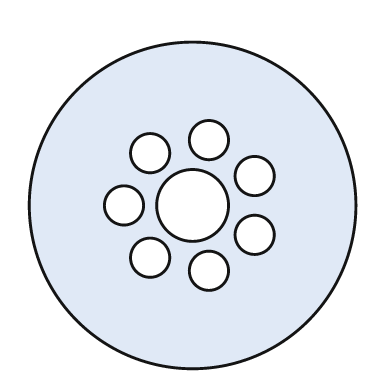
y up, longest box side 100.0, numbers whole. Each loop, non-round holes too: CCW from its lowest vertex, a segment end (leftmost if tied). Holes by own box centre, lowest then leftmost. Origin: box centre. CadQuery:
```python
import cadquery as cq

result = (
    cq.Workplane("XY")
    .moveTo(0.0, 0.0)
    .circle(50.0)
    .moveTo(5.0, -20.0)
    .circle(6.0)
    .moveTo(-13.0, -16.0)
    .circle(6.0)
    .moveTo(19.0, -9.0)
    .circle(6.0)
    .moveTo(-21.0, 0.0)
    .circle(6.0)
    .moveTo(0.0, 0.0)
    .circle(11.0)
    .moveTo(19.0, 9.0)
    .circle(6.0)
    .moveTo(-13.0, 16.0)
    .circle(6.0)
    .moveTo(5.0, 20.0)
    .circle(6.0)
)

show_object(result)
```